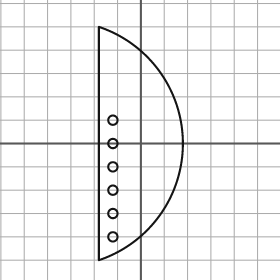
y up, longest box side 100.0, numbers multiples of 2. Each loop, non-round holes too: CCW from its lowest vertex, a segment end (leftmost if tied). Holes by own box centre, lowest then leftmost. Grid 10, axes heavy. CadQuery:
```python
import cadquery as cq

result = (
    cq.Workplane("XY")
    .moveTo(-18.0, -50.0)
    .threePointArc((18.0, 0.0), (-18.0, 50.0))
    .close()
    .moveTo(-12.0, -40.0)
    .circle(2.0)
    .moveTo(-12.0, -30.0)
    .circle(2.0)
    .moveTo(-12.0, -20.0)
    .circle(2.0)
    .moveTo(-12.0, -10.0)
    .circle(2.0)
    .moveTo(-12.0, 0.0)
    .circle(2.0)
    .moveTo(-12.0, 10.0)
    .circle(2.0)
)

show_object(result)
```